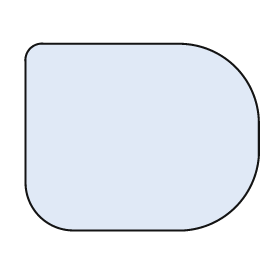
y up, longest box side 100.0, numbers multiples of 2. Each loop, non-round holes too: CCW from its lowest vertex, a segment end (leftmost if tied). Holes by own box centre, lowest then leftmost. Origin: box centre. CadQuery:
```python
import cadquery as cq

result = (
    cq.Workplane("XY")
    .moveTo(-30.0, -40.0)
    .lineTo(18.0, -40.0)
    .threePointArc((40.0, -30.0), (50.0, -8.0))
    .lineTo(50.0, 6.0)
    .threePointArc((40.0, 30.0), (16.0, 40.0))
    .lineTo(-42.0, 40.0)
    .threePointArc((-48.0, 38.0), (-50.0, 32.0))
    .lineTo(-50.0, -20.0)
    .threePointArc((-44.0, -34.0), (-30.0, -40.0))
    .close()
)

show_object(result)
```